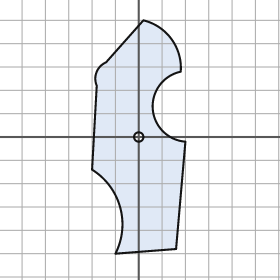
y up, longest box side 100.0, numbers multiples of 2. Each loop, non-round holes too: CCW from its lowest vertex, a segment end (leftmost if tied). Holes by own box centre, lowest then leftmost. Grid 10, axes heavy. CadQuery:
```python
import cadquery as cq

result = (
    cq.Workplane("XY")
    .moveTo(-10.0, -50.0)
    .lineTo(16.0, -48.0)
    .lineTo(20.0, -2.0)
    .threePointArc((6.0, 12.0), (18.0, 28.0))
    .threePointArc((14.0, 42.0), (2.0, 50.0))
    .lineTo(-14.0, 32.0)
    .threePointArc((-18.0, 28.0), (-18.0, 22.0))
    .lineTo(-20.0, -14.0)
    .threePointArc((-8.0, -30.0), (-10.0, -50.0))
    .close()
    .moveTo(0.0, 0.0)
    .circle(2.0)
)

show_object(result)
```